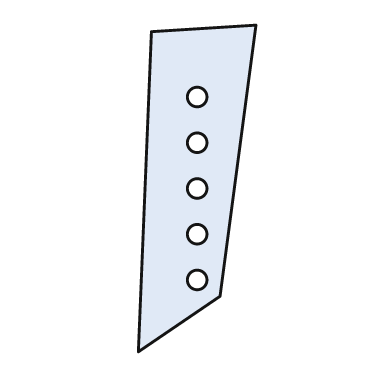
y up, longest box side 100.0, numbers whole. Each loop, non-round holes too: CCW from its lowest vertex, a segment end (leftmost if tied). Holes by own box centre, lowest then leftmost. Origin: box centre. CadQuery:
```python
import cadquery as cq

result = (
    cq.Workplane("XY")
    .moveTo(-18.0, -50.0)
    .lineTo(7.0, -33.0)
    .lineTo(18.0, 50.0)
    .lineTo(-14.0, 48.0)
    .close()
    .moveTo(0.0, -28.0)
    .circle(3.0)
    .moveTo(0.0, -14.0)
    .circle(3.0)
    .moveTo(0.0, 0.0)
    .circle(3.0)
    .moveTo(0.0, 14.0)
    .circle(3.0)
    .moveTo(0.0, 28.0)
    .circle(3.0)
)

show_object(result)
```